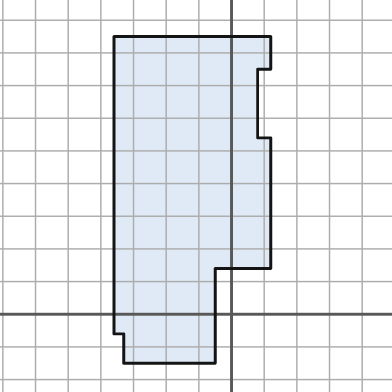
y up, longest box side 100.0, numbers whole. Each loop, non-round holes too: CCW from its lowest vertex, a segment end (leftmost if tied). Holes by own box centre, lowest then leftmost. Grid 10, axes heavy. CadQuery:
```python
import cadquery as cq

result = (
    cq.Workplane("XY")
    .moveTo(-33.0, -15.0)
    .lineTo(-5.0, -15.0)
    .lineTo(-5.0, 14.0)
    .lineTo(12.0, 14.0)
    .lineTo(12.0, 54.0)
    .lineTo(8.0, 54.0)
    .lineTo(8.0, 75.0)
    .lineTo(12.0, 75.0)
    .lineTo(12.0, 85.0)
    .lineTo(-36.0, 85.0)
    .lineTo(-36.0, -6.0)
    .lineTo(-33.0, -6.0)
    .close()
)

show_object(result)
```